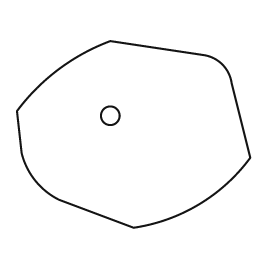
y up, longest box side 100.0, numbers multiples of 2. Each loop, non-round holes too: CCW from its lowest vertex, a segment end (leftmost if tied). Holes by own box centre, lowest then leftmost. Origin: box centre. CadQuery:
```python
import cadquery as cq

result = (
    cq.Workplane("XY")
    .moveTo(0.0, -40.0)
    .threePointArc((28.0, -30.0), (50.0, -10.0))
    .lineTo(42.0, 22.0)
    .threePointArc((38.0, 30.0), (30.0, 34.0))
    .lineTo(-10.0, 40.0)
    .threePointArc((-32.0, 28.0), (-50.0, 10.0))
    .lineTo(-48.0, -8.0)
    .threePointArc((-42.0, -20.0), (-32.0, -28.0))
    .close()
    .moveTo(-10.0, 8.0)
    .circle(4.0)
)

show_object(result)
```